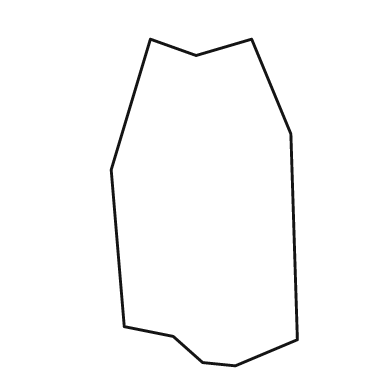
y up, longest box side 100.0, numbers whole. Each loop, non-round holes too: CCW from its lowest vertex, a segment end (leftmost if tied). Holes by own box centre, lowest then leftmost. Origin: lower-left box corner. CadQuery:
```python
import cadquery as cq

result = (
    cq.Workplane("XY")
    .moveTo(38.0, 0.0)
    .lineTo(57.0, 8.0)
    .lineTo(55.0, 71.0)
    .lineTo(43.0, 100.0)
    .lineTo(26.0, 95.0)
    .lineTo(12.0, 100.0)
    .lineTo(0.0, 60.0)
    .lineTo(4.0, 12.0)
    .lineTo(19.0, 9.0)
    .lineTo(28.0, 1.0)
    .close()
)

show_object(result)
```